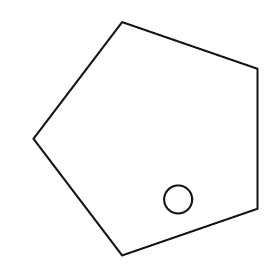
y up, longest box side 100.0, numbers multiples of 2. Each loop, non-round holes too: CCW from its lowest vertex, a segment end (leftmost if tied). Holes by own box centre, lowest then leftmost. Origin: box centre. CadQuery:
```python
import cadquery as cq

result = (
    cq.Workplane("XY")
    .moveTo(-10.0, -50.0)
    .lineTo(48.0, -30.0)
    .lineTo(48.0, 30.0)
    .lineTo(-10.0, 50.0)
    .lineTo(-48.0, 0.0)
    .close()
    .moveTo(14.0, -26.0)
    .circle(6.0)
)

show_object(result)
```